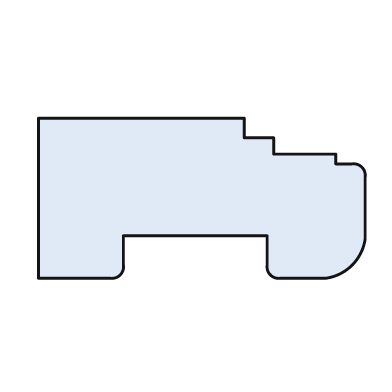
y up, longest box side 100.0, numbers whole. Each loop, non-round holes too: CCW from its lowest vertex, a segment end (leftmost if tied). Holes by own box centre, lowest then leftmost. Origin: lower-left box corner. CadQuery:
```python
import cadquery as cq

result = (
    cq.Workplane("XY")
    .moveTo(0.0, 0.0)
    .lineTo(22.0, 0.0)
    .threePointArc((25.0, 1.0), (26.0, 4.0))
    .lineTo(26.0, 13.0)
    .lineTo(70.0, 13.0)
    .lineTo(70.0, 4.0)
    .threePointArc((71.0, 1.0), (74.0, 0.0))
    .lineTo(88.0, 0.0)
    .threePointArc((96.0, 4.0), (100.0, 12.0))
    .lineTo(100.0, 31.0)
    .threePointArc((99.0, 34.0), (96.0, 35.0))
    .lineTo(91.0, 35.0)
    .lineTo(91.0, 38.0)
    .lineTo(72.0, 38.0)
    .lineTo(72.0, 43.0)
    .lineTo(63.0, 43.0)
    .lineTo(63.0, 49.0)
    .lineTo(0.0, 49.0)
    .close()
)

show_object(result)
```